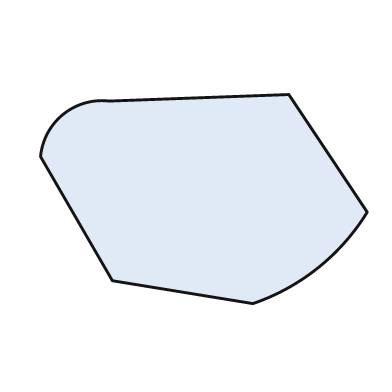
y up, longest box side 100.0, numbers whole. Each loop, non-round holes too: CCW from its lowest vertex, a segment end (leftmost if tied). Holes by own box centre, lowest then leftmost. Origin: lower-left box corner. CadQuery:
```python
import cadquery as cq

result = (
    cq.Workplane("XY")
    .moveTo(65.0, 0.0)
    .threePointArc((85.0, 11.0), (100.0, 28.0))
    .lineTo(76.0, 64.0)
    .lineTo(21.0, 62.0)
    .threePointArc((7.0, 58.0), (0.0, 45.0))
    .lineTo(22.0, 7.0)
    .close()
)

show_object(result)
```